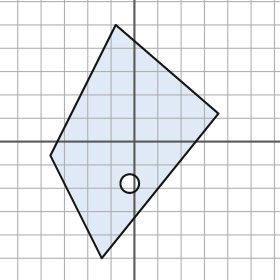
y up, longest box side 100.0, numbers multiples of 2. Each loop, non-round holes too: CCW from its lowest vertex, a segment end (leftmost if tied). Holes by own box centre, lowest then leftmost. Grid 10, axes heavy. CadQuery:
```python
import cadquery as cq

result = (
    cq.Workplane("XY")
    .moveTo(-14.0, -50.0)
    .lineTo(36.0, 12.0)
    .lineTo(-8.0, 50.0)
    .lineTo(-36.0, -6.0)
    .close()
    .moveTo(-2.0, -18.0)
    .circle(4.0)
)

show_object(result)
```